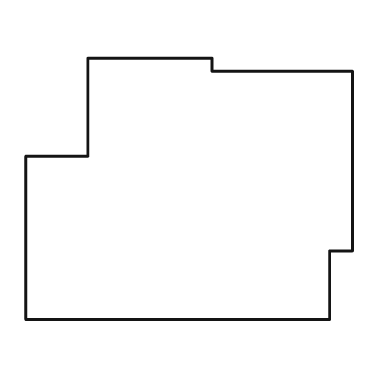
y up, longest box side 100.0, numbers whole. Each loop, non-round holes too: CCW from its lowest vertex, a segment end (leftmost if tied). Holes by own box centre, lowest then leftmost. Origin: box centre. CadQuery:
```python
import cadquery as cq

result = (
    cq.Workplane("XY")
    .moveTo(-50.0, -40.0)
    .lineTo(43.0, -40.0)
    .lineTo(43.0, -19.0)
    .lineTo(50.0, -19.0)
    .lineTo(50.0, 36.0)
    .lineTo(7.0, 36.0)
    .lineTo(7.0, 40.0)
    .lineTo(-31.0, 40.0)
    .lineTo(-31.0, 10.0)
    .lineTo(-50.0, 10.0)
    .close()
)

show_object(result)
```